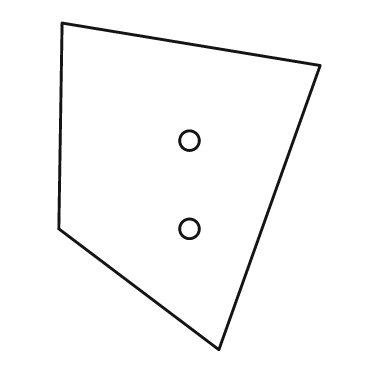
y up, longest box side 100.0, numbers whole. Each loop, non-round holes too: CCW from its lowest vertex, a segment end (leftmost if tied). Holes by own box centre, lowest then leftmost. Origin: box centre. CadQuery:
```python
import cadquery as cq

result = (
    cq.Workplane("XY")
    .moveTo(9.0, -50.0)
    .lineTo(40.0, 37.0)
    .lineTo(-39.0, 50.0)
    .lineTo(-40.0, -13.0)
    .close()
    .moveTo(0.0, -13.0)
    .circle(3.0)
    .moveTo(0.0, 14.0)
    .circle(3.0)
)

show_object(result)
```